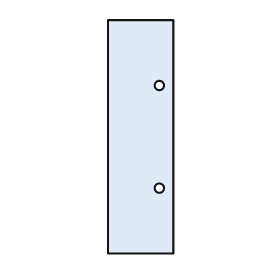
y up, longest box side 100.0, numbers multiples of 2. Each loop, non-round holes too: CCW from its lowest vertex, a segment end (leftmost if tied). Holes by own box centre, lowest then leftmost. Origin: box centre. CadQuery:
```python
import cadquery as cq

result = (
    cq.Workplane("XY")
    .moveTo(-14.0, -50.0)
    .lineTo(14.0, -50.0)
    .lineTo(14.0, 50.0)
    .lineTo(-14.0, 50.0)
    .close()
    .moveTo(8.0, -22.0)
    .circle(2.0)
    .moveTo(8.0, 22.0)
    .circle(2.0)
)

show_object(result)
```